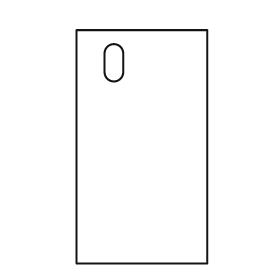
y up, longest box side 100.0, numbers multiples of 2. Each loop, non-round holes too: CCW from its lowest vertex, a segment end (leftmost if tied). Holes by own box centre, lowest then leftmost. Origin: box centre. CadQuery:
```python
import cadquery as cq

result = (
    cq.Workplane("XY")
    .moveTo(-28.0, -50.0)
    .lineTo(28.0, -50.0)
    .lineTo(28.0, 50.0)
    .lineTo(-28.0, 50.0)
    .close()
    .moveTo(-16.0, 32.0)
    .threePointArc((-12.0, 28.0), (-8.0, 32.0))
    .lineTo(-8.0, 40.0)
    .threePointArc((-12.0, 44.0), (-16.0, 40.0))
    .close()
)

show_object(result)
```